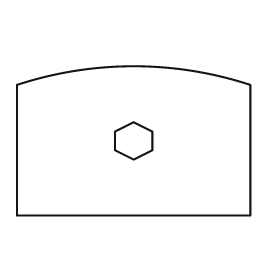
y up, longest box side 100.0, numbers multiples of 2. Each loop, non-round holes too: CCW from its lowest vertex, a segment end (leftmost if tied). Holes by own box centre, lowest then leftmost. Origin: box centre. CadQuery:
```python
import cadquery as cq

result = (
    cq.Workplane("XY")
    .moveTo(-50.0, -32.0)
    .lineTo(50.0, -32.0)
    .lineTo(50.0, 24.0)
    .threePointArc((0.0, 32.0), (-50.0, 24.0))
    .close()
    .moveTo(0.0, -8.0)
    .lineTo(8.0, -4.0)
    .lineTo(8.0, 4.0)
    .lineTo(0.0, 8.0)
    .lineTo(-8.0, 4.0)
    .lineTo(-8.0, -4.0)
    .close()
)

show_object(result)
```